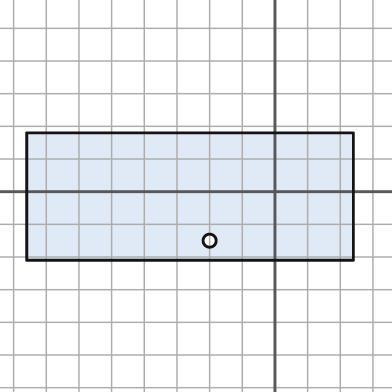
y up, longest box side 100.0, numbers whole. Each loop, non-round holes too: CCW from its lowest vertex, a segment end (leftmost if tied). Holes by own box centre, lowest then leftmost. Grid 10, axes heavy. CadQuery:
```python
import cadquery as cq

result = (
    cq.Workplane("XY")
    .moveTo(-76.0, -21.0)
    .lineTo(24.0, -21.0)
    .lineTo(24.0, 18.0)
    .lineTo(-76.0, 18.0)
    .close()
    .moveTo(-20.0, -15.0)
    .circle(2.0)
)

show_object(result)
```